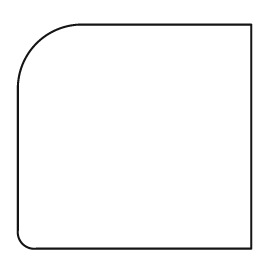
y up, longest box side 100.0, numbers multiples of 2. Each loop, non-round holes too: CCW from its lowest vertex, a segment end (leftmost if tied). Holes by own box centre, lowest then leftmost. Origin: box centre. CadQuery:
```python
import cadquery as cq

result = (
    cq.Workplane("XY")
    .moveTo(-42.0, -48.0)
    .lineTo(50.0, -48.0)
    .lineTo(50.0, 48.0)
    .lineTo(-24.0, 48.0)
    .threePointArc((-42.0, 40.0), (-50.0, 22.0))
    .lineTo(-50.0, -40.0)
    .threePointArc((-48.0, -46.0), (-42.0, -48.0))
    .close()
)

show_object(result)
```